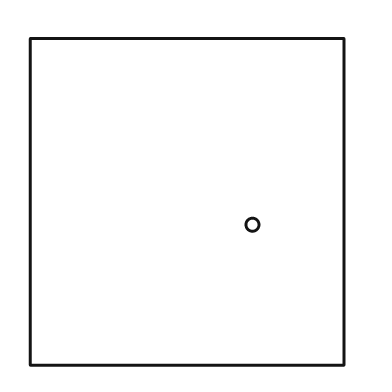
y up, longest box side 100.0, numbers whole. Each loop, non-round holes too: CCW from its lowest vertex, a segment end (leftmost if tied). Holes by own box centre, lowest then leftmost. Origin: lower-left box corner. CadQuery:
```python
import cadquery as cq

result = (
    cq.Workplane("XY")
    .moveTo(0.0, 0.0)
    .lineTo(96.0, 0.0)
    .lineTo(96.0, 100.0)
    .lineTo(0.0, 100.0)
    .close()
    .moveTo(68.0, 43.0)
    .circle(2.0)
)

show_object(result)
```